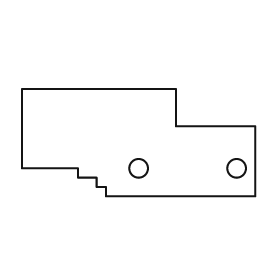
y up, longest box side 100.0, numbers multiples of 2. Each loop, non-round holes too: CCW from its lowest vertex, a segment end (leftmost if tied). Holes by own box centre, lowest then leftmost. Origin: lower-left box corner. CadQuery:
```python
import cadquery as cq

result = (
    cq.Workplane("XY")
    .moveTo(36.0, 0.0)
    .lineTo(100.0, 0.0)
    .lineTo(100.0, 30.0)
    .lineTo(66.0, 30.0)
    .lineTo(66.0, 46.0)
    .lineTo(0.0, 46.0)
    .lineTo(0.0, 12.0)
    .lineTo(24.0, 12.0)
    .lineTo(24.0, 8.0)
    .lineTo(32.0, 8.0)
    .lineTo(32.0, 4.0)
    .lineTo(36.0, 4.0)
    .close()
    .moveTo(50.0, 12.0)
    .circle(4.0)
    .moveTo(92.0, 12.0)
    .circle(4.0)
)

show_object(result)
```